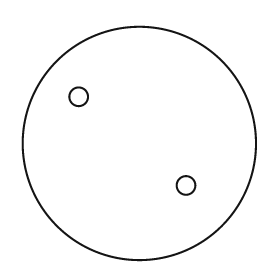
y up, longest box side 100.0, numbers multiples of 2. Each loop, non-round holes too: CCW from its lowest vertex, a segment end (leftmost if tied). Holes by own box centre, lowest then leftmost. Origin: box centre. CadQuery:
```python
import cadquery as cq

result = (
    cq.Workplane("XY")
    .moveTo(0.0, 0.0)
    .circle(50.0)
    .moveTo(20.0, -18.0)
    .circle(4.0)
    .moveTo(-26.0, 20.0)
    .circle(4.0)
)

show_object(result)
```